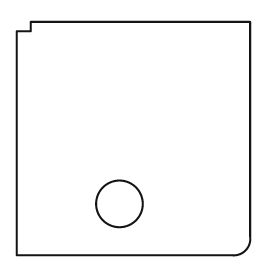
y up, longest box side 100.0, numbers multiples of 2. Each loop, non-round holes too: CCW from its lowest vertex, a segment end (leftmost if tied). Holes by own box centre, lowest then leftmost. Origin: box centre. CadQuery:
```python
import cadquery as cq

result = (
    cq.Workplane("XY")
    .moveTo(-50.0, -50.0)
    .lineTo(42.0, -50.0)
    .threePointArc((48.0, -48.0), (50.0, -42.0))
    .lineTo(50.0, 50.0)
    .lineTo(-44.0, 50.0)
    .lineTo(-44.0, 46.0)
    .lineTo(-50.0, 46.0)
    .close()
    .moveTo(-6.0, -28.0)
    .circle(10.0)
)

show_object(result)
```